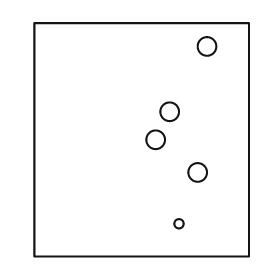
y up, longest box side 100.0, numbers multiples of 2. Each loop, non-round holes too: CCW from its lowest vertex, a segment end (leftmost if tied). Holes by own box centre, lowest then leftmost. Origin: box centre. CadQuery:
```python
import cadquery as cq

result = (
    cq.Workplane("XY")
    .moveTo(-46.0, -50.0)
    .lineTo(46.0, -50.0)
    .lineTo(46.0, 50.0)
    .lineTo(-46.0, 50.0)
    .close()
    .moveTo(16.0, -36.0)
    .circle(2.0)
    .moveTo(24.0, -14.0)
    .circle(4.0)
    .moveTo(6.0, 0.0)
    .circle(4.0)
    .moveTo(12.0, 12.0)
    .circle(4.0)
    .moveTo(28.0, 40.0)
    .circle(4.0)
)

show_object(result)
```